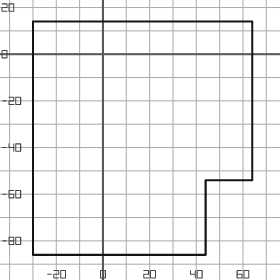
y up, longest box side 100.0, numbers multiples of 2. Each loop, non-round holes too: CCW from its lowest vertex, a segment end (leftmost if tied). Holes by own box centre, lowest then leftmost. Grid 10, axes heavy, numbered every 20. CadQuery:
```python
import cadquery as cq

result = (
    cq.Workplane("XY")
    .moveTo(-30.0, -86.0)
    .lineTo(44.0, -86.0)
    .lineTo(44.0, -54.0)
    .lineTo(64.0, -54.0)
    .lineTo(64.0, 14.0)
    .lineTo(-30.0, 14.0)
    .close()
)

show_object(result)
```